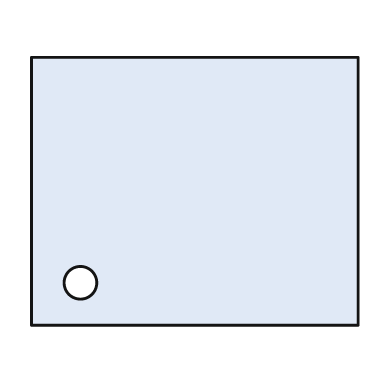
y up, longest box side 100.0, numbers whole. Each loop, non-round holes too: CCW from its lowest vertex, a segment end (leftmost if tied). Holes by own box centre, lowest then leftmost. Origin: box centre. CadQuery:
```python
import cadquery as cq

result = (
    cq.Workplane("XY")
    .moveTo(-50.0, -41.0)
    .lineTo(50.0, -41.0)
    .lineTo(50.0, 41.0)
    .lineTo(-50.0, 41.0)
    .close()
    .moveTo(-35.0, -28.0)
    .circle(5.0)
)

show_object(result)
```